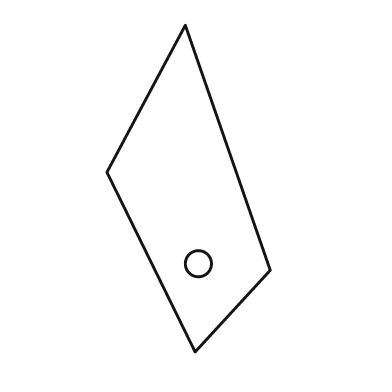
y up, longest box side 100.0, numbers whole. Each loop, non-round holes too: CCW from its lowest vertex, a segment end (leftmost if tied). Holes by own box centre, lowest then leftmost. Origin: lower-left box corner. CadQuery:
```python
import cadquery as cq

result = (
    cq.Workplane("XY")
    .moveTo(27.0, 0.0)
    .lineTo(50.0, 25.0)
    .lineTo(24.0, 100.0)
    .lineTo(0.0, 55.0)
    .close()
    .moveTo(28.0, 27.0)
    .circle(4.0)
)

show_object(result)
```